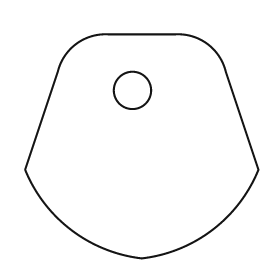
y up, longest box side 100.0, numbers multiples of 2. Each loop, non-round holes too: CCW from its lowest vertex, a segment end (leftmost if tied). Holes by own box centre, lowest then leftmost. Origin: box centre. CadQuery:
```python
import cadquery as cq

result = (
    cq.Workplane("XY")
    .moveTo(0.0, -48.0)
    .threePointArc((30.0, -36.0), (50.0, -10.0))
    .lineTo(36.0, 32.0)
    .threePointArc((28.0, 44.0), (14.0, 48.0))
    .lineTo(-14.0, 48.0)
    .threePointArc((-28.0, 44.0), (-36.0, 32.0))
    .lineTo(-50.0, -10.0)
    .threePointArc((-30.0, -36.0), (0.0, -48.0))
    .close()
    .moveTo(-4.0, 24.0)
    .circle(8.0)
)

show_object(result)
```